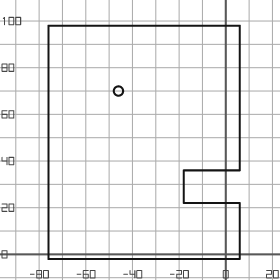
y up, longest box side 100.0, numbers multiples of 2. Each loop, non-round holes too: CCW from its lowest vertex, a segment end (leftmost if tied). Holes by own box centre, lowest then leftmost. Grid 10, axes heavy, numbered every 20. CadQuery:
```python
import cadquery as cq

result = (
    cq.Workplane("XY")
    .moveTo(-76.0, -2.0)
    .lineTo(6.0, -2.0)
    .lineTo(6.0, 22.0)
    .lineTo(-18.0, 22.0)
    .lineTo(-18.0, 36.0)
    .lineTo(6.0, 36.0)
    .lineTo(6.0, 98.0)
    .lineTo(-76.0, 98.0)
    .close()
    .moveTo(-46.0, 70.0)
    .circle(2.0)
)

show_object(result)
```